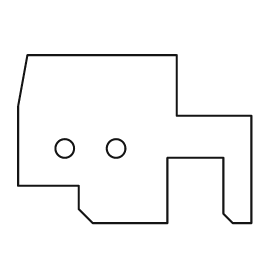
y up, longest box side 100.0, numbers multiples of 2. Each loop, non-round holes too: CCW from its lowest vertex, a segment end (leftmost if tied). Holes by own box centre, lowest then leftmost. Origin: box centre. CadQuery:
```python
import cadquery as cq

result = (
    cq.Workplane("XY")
    .moveTo(-18.0, -36.0)
    .lineTo(14.0, -36.0)
    .lineTo(14.0, -8.0)
    .lineTo(38.0, -8.0)
    .lineTo(38.0, -32.0)
    .lineTo(42.0, -36.0)
    .lineTo(50.0, -36.0)
    .lineTo(50.0, 10.0)
    .lineTo(18.0, 10.0)
    .lineTo(18.0, 36.0)
    .lineTo(-46.0, 36.0)
    .lineTo(-50.0, 14.0)
    .lineTo(-50.0, -20.0)
    .lineTo(-24.0, -20.0)
    .lineTo(-24.0, -30.0)
    .close()
    .moveTo(-30.0, -4.0)
    .circle(4.0)
    .moveTo(-8.0, -4.0)
    .circle(4.0)
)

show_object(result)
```